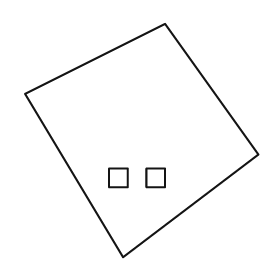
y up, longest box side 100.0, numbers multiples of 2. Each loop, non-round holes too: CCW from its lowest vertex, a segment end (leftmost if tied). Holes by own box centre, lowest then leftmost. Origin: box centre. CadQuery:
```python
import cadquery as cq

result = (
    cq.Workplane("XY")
    .moveTo(-8.0, -50.0)
    .lineTo(50.0, -6.0)
    .lineTo(10.0, 50.0)
    .lineTo(-50.0, 20.0)
    .close()
    .moveTo(-14.0, -20.0)
    .lineTo(-6.0, -20.0)
    .lineTo(-6.0, -12.0)
    .lineTo(-14.0, -12.0)
    .close()
    .moveTo(2.0, -20.0)
    .lineTo(10.0, -20.0)
    .lineTo(10.0, -12.0)
    .lineTo(2.0, -12.0)
    .close()
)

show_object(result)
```